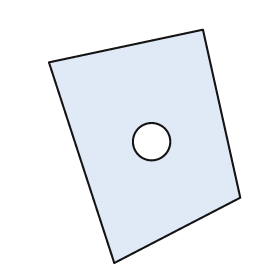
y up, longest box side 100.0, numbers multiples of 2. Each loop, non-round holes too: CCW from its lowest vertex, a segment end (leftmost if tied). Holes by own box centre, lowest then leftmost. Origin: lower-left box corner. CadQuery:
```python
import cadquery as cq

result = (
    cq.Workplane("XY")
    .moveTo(28.0, 0.0)
    .lineTo(82.0, 28.0)
    .lineTo(66.0, 100.0)
    .lineTo(0.0, 86.0)
    .close()
    .moveTo(44.0, 52.0)
    .circle(8.0)
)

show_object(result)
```